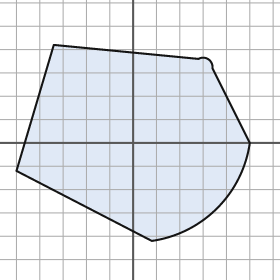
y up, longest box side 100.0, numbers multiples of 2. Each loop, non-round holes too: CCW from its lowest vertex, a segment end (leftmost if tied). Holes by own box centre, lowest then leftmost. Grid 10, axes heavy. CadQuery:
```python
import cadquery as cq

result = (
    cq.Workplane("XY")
    .moveTo(8.0, -42.0)
    .threePointArc((36.0, -28.0), (50.0, 0.0))
    .lineTo(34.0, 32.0)
    .threePointArc((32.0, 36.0), (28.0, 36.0))
    .lineTo(-34.0, 42.0)
    .lineTo(-50.0, -12.0)
    .close()
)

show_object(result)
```